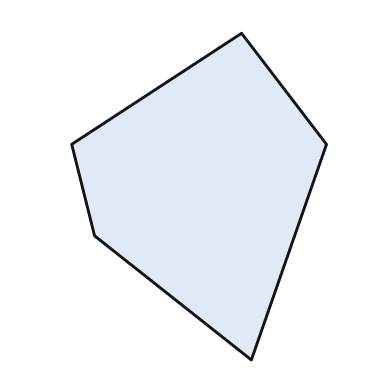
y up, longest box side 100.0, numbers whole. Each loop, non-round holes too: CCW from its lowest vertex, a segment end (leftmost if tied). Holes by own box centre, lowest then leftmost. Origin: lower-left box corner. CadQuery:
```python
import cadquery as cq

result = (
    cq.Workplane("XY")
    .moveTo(55.0, 0.0)
    .lineTo(78.0, 66.0)
    .lineTo(52.0, 100.0)
    .lineTo(0.0, 66.0)
    .lineTo(7.0, 38.0)
    .close()
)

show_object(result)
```